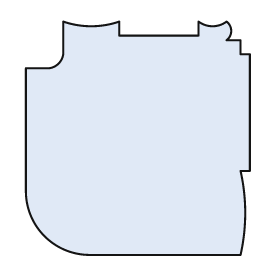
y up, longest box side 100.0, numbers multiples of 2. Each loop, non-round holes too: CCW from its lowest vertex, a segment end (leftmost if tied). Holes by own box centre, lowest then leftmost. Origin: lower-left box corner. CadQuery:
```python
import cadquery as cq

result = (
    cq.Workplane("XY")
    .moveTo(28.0, 0.0)
    .lineTo(92.0, 0.0)
    .threePointArc((94.0, 18.0), (92.0, 36.0))
    .lineTo(96.0, 36.0)
    .lineTo(96.0, 86.0)
    .lineTo(92.0, 86.0)
    .lineTo(92.0, 92.0)
    .lineTo(86.0, 92.0)
    .threePointArc((88.0, 96.0), (86.0, 100.0))
    .threePointArc((80.0, 98.0), (74.0, 100.0))
    .lineTo(74.0, 94.0)
    .lineTo(40.0, 94.0)
    .lineTo(40.0, 100.0)
    .threePointArc((28.0, 98.0), (16.0, 100.0))
    .lineTo(16.0, 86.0)
    .threePointArc((14.0, 82.0), (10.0, 80.0))
    .lineTo(0.0, 80.0)
    .lineTo(0.0, 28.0)
    .threePointArc((8.0, 8.0), (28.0, 0.0))
    .close()
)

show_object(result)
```